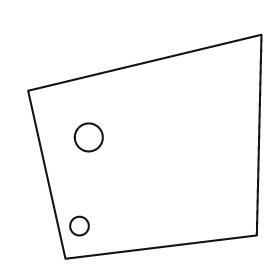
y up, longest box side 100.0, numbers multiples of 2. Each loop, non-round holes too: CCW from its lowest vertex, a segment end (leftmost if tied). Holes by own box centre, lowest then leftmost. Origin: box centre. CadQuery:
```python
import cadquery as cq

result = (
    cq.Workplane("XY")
    .moveTo(-34.0, -48.0)
    .lineTo(48.0, -38.0)
    .lineTo(50.0, 48.0)
    .lineTo(-50.0, 24.0)
    .close()
    .moveTo(-28.0, -34.0)
    .circle(4.0)
    .moveTo(-24.0, 4.0)
    .circle(6.0)
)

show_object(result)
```